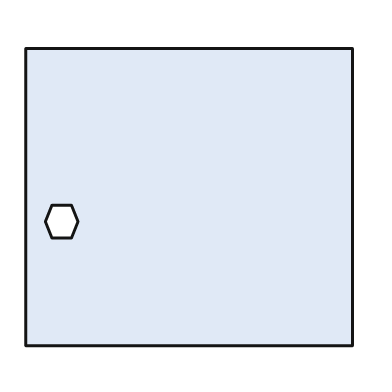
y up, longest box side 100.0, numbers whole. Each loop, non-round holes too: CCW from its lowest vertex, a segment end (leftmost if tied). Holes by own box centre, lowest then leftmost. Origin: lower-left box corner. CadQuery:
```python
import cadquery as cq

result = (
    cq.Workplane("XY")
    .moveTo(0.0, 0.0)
    .lineTo(100.0, 0.0)
    .lineTo(100.0, 91.0)
    .lineTo(0.0, 91.0)
    .close()
    .moveTo(8.0, 33.0)
    .lineTo(14.0, 33.0)
    .lineTo(16.0, 38.0)
    .lineTo(14.0, 43.0)
    .lineTo(8.0, 43.0)
    .lineTo(6.0, 38.0)
    .close()
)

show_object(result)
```